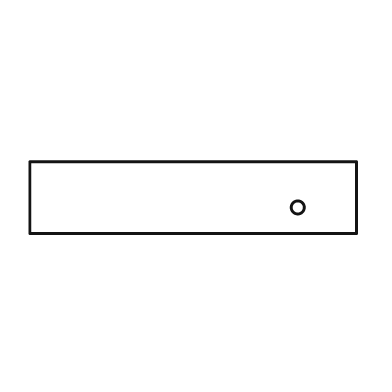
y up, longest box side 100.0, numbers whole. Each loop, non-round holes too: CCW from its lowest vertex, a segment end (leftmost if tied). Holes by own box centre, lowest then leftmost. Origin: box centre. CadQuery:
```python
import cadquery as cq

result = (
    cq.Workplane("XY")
    .moveTo(-50.0, -11.0)
    .lineTo(50.0, -11.0)
    .lineTo(50.0, 11.0)
    .lineTo(-50.0, 11.0)
    .close()
    .moveTo(32.0, -3.0)
    .circle(2.0)
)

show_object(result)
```